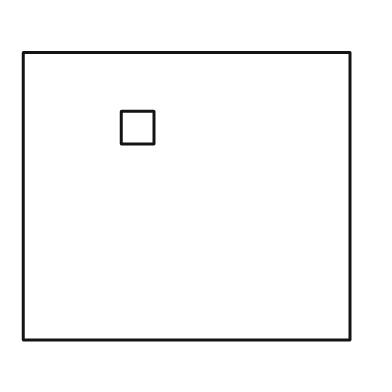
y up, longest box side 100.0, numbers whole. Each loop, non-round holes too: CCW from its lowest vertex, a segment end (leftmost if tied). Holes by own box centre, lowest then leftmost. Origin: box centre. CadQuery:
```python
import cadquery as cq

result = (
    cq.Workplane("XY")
    .moveTo(-50.0, -44.0)
    .lineTo(50.0, -44.0)
    .lineTo(50.0, 44.0)
    .lineTo(-50.0, 44.0)
    .close()
    .moveTo(-20.0, 16.0)
    .lineTo(-10.0, 16.0)
    .lineTo(-10.0, 26.0)
    .lineTo(-20.0, 26.0)
    .close()
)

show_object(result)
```